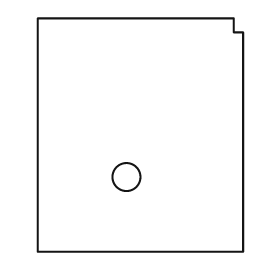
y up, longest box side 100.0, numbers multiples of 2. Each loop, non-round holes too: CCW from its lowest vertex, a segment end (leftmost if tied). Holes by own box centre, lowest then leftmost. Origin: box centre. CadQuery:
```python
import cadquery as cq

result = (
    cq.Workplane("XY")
    .moveTo(-44.0, -50.0)
    .lineTo(44.0, -50.0)
    .lineTo(44.0, 44.0)
    .lineTo(40.0, 44.0)
    .lineTo(40.0, 50.0)
    .lineTo(-44.0, 50.0)
    .close()
    .moveTo(-6.0, -18.0)
    .circle(6.0)
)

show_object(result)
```